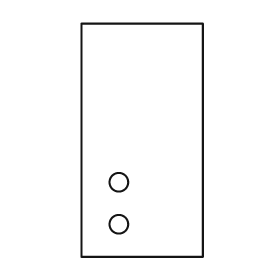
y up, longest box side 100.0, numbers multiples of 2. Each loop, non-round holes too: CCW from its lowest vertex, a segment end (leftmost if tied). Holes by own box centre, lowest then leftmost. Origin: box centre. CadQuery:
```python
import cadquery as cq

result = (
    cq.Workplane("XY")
    .moveTo(-26.0, -50.0)
    .lineTo(26.0, -50.0)
    .lineTo(26.0, 50.0)
    .lineTo(-26.0, 50.0)
    .close()
    .moveTo(-10.0, -36.0)
    .circle(4.0)
    .moveTo(-10.0, -18.0)
    .circle(4.0)
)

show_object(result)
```